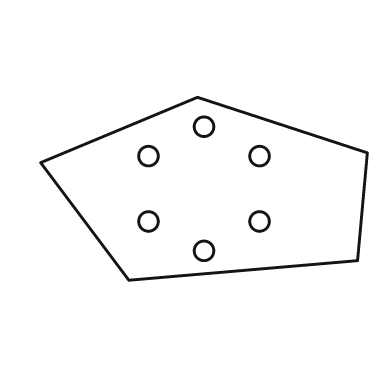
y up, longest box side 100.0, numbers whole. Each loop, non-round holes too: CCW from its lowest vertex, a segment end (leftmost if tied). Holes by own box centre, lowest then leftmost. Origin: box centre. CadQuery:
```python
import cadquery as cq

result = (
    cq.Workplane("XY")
    .moveTo(-23.0, -28.0)
    .lineTo(47.0, -22.0)
    .lineTo(50.0, 11.0)
    .lineTo(-2.0, 28.0)
    .lineTo(-50.0, 8.0)
    .close()
    .moveTo(0.0, -19.0)
    .circle(3.0)
    .moveTo(-17.0, -10.0)
    .circle(3.0)
    .moveTo(17.0, -10.0)
    .circle(3.0)
    .moveTo(-17.0, 10.0)
    .circle(3.0)
    .moveTo(17.0, 10.0)
    .circle(3.0)
    .moveTo(0.0, 19.0)
    .circle(3.0)
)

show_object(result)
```